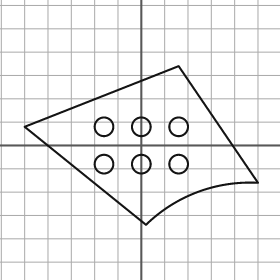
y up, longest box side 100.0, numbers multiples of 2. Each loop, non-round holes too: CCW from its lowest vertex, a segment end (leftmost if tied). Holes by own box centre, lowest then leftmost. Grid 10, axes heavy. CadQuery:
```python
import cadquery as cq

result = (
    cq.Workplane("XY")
    .moveTo(2.0, -34.0)
    .threePointArc((24.0, -20.0), (50.0, -16.0))
    .lineTo(16.0, 34.0)
    .lineTo(-50.0, 8.0)
    .close()
    .moveTo(-16.0, -8.0)
    .circle(4.0)
    .moveTo(0.0, -8.0)
    .circle(4.0)
    .moveTo(16.0, -8.0)
    .circle(4.0)
    .moveTo(-16.0, 8.0)
    .circle(4.0)
    .moveTo(0.0, 8.0)
    .circle(4.0)
    .moveTo(16.0, 8.0)
    .circle(4.0)
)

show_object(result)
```